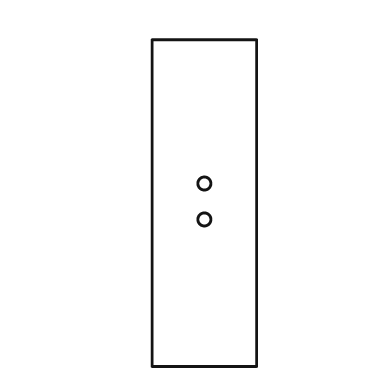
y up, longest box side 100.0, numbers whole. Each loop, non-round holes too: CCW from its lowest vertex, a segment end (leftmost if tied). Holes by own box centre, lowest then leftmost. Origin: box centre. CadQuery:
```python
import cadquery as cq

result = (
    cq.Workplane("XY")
    .moveTo(-16.0, -50.0)
    .lineTo(16.0, -50.0)
    .lineTo(16.0, 50.0)
    .lineTo(-16.0, 50.0)
    .close()
    .moveTo(0.0, -5.0)
    .circle(2.0)
    .moveTo(0.0, 6.0)
    .circle(2.0)
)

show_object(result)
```